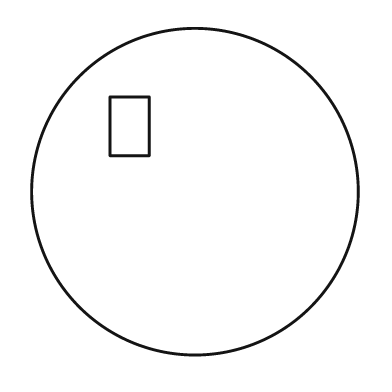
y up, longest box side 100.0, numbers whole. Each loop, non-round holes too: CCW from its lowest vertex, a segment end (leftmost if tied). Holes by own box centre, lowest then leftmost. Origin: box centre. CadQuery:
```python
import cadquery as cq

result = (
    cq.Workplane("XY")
    .moveTo(0.0, 0.0)
    .circle(50.0)
    .moveTo(-26.0, 11.0)
    .lineTo(-14.0, 11.0)
    .lineTo(-14.0, 29.0)
    .lineTo(-26.0, 29.0)
    .close()
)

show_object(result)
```